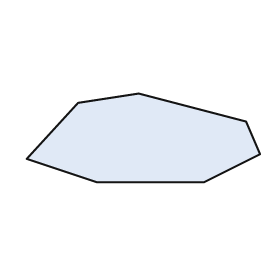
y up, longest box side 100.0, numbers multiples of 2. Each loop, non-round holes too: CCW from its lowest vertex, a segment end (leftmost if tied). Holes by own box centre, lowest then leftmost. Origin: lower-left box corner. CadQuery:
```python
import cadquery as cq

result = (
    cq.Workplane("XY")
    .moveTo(30.0, 0.0)
    .lineTo(76.0, 0.0)
    .lineTo(100.0, 12.0)
    .lineTo(94.0, 26.0)
    .lineTo(48.0, 38.0)
    .lineTo(22.0, 34.0)
    .lineTo(0.0, 10.0)
    .close()
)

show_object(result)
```